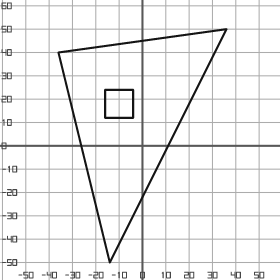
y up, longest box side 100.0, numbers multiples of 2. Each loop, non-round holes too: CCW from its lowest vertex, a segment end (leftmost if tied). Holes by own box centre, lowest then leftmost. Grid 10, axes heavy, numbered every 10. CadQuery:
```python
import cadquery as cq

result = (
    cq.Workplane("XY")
    .moveTo(-14.0, -50.0)
    .lineTo(36.0, 50.0)
    .lineTo(-36.0, 40.0)
    .close()
    .moveTo(-16.0, 12.0)
    .lineTo(-4.0, 12.0)
    .lineTo(-4.0, 24.0)
    .lineTo(-16.0, 24.0)
    .close()
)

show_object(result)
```